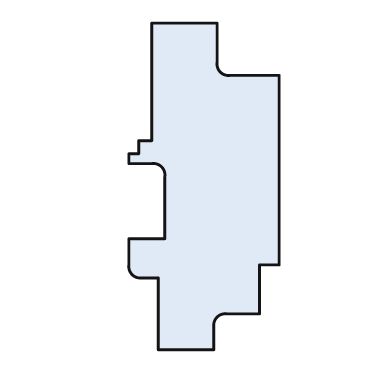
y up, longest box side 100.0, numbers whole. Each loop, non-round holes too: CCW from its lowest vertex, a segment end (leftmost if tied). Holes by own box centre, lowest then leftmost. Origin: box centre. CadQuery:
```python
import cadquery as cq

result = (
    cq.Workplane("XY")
    .moveTo(-14.0, -50.0)
    .lineTo(3.0, -50.0)
    .lineTo(3.0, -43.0)
    .threePointArc((4.0, -40.0), (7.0, -39.0))
    .lineTo(17.0, -39.0)
    .lineTo(17.0, -24.0)
    .lineTo(23.0, -24.0)
    .lineTo(23.0, 34.0)
    .lineTo(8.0, 34.0)
    .threePointArc((5.0, 35.0), (4.0, 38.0))
    .lineTo(4.0, 50.0)
    .lineTo(-16.0, 50.0)
    .lineTo(-16.0, 14.0)
    .lineTo(-20.0, 14.0)
    .lineTo(-20.0, 10.0)
    .lineTo(-23.0, 10.0)
    .lineTo(-23.0, 7.0)
    .lineTo(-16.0, 7.0)
    .threePointArc((-13.0, 6.0), (-12.0, 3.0))
    .lineTo(-12.0, -16.0)
    .lineTo(-23.0, -16.0)
    .lineTo(-23.0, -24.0)
    .threePointArc((-22.0, -27.0), (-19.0, -28.0))
    .lineTo(-14.0, -28.0)
    .close()
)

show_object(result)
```